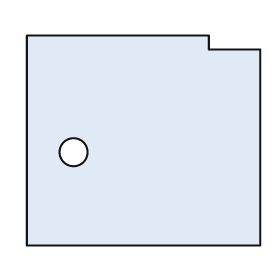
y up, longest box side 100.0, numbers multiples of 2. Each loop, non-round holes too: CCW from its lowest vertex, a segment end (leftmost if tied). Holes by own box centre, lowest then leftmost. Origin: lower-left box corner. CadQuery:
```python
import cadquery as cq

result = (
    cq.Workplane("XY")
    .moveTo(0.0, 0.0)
    .lineTo(100.0, 0.0)
    .lineTo(100.0, 84.0)
    .lineTo(78.0, 84.0)
    .lineTo(78.0, 90.0)
    .lineTo(0.0, 90.0)
    .close()
    .moveTo(20.0, 40.0)
    .circle(6.0)
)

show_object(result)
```